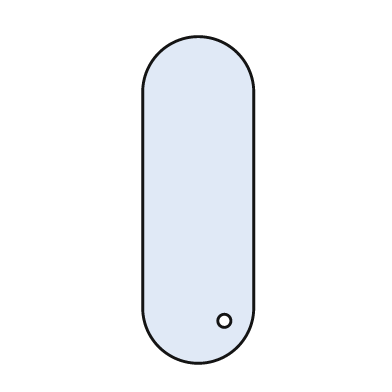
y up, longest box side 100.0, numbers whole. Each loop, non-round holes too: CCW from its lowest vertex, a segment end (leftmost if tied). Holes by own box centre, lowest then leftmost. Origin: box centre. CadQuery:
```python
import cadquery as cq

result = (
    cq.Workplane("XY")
    .moveTo(-17.0, -33.0)
    .threePointArc((0.0, -50.0), (17.0, -33.0))
    .lineTo(17.0, 33.0)
    .threePointArc((0.0, 50.0), (-17.0, 33.0))
    .close()
    .moveTo(8.0, -37.0)
    .circle(2.0)
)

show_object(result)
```